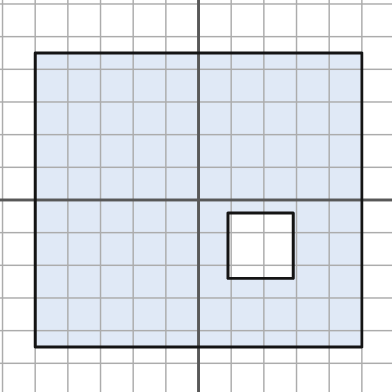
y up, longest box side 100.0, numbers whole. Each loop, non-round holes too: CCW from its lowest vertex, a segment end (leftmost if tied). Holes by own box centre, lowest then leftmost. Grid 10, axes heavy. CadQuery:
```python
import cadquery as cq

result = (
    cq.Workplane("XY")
    .moveTo(-50.0, -45.0)
    .lineTo(50.0, -45.0)
    .lineTo(50.0, 45.0)
    .lineTo(-50.0, 45.0)
    .close()
    .moveTo(9.0, -24.0)
    .lineTo(29.0, -24.0)
    .lineTo(29.0, -4.0)
    .lineTo(9.0, -4.0)
    .close()
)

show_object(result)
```